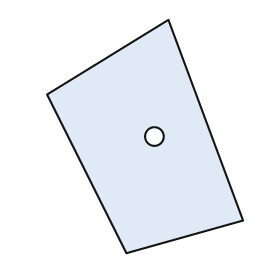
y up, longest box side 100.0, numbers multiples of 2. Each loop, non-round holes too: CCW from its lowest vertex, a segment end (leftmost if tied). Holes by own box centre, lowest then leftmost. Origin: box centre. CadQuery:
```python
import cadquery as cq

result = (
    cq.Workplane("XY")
    .moveTo(-8.0, -50.0)
    .lineTo(42.0, -36.0)
    .lineTo(10.0, 50.0)
    .lineTo(-42.0, 18.0)
    .close()
    .moveTo(4.0, 0.0)
    .circle(4.0)
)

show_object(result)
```